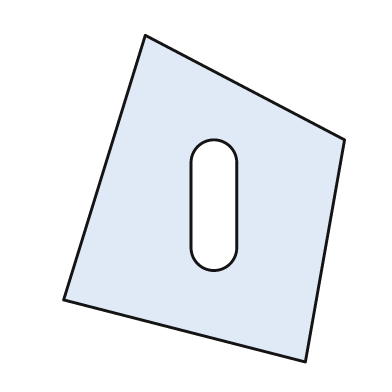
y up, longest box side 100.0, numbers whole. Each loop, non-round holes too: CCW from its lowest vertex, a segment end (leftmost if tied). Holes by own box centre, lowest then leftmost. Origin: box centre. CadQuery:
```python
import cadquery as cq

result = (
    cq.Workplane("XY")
    .moveTo(31.0, -50.0)
    .lineTo(43.0, 18.0)
    .lineTo(-18.0, 50.0)
    .lineTo(-43.0, -31.0)
    .close()
    .moveTo(-4.0, -15.0)
    .threePointArc((3.0, -22.0), (10.0, -15.0))
    .lineTo(10.0, 11.0)
    .threePointArc((3.0, 18.0), (-4.0, 11.0))
    .close()
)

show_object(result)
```